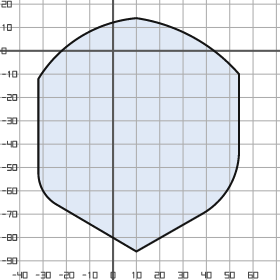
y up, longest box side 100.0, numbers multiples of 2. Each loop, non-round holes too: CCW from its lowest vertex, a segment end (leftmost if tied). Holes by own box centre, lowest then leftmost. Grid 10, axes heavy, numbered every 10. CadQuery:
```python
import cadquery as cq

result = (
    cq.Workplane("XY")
    .moveTo(10.0, -86.0)
    .lineTo(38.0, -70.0)
    .threePointArc((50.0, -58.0), (54.0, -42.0))
    .lineTo(54.0, -10.0)
    .threePointArc((34.0, 6.0), (10.0, 14.0))
    .threePointArc((-14.0, 6.0), (-32.0, -12.0))
    .lineTo(-32.0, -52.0)
    .threePointArc((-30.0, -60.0), (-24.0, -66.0))
    .close()
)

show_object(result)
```